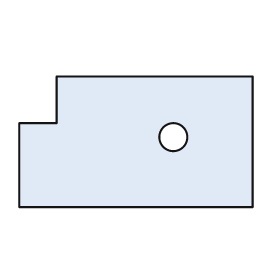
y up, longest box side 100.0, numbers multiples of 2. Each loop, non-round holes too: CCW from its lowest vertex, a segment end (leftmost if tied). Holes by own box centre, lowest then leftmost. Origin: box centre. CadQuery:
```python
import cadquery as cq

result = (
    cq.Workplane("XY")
    .moveTo(-50.0, -28.0)
    .lineTo(50.0, -28.0)
    .lineTo(50.0, 28.0)
    .lineTo(-34.0, 28.0)
    .lineTo(-34.0, 8.0)
    .lineTo(-50.0, 8.0)
    .close()
    .moveTo(16.0, 2.0)
    .circle(6.0)
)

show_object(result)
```